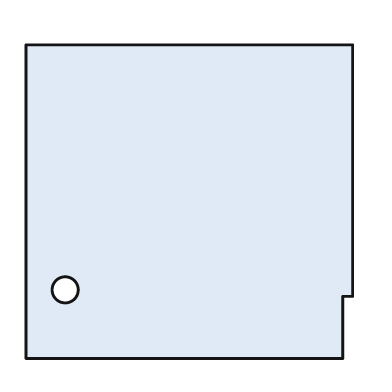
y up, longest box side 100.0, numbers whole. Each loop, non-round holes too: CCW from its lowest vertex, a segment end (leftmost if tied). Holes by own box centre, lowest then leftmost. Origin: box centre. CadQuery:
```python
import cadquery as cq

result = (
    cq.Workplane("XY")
    .moveTo(-50.0, -48.0)
    .lineTo(47.0, -48.0)
    .lineTo(47.0, -29.0)
    .lineTo(50.0, -29.0)
    .lineTo(50.0, 48.0)
    .lineTo(-50.0, 48.0)
    .close()
    .moveTo(-38.0, -27.0)
    .circle(4.0)
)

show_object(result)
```